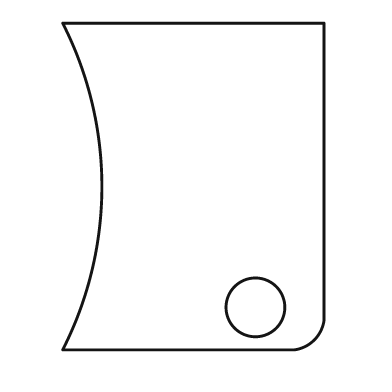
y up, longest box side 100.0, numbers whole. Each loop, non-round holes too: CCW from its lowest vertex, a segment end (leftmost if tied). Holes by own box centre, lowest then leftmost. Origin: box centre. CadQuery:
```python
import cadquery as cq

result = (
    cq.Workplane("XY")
    .moveTo(-40.0, -50.0)
    .lineTo(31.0, -50.0)
    .threePointArc((37.0, -47.0), (40.0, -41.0))
    .lineTo(40.0, 50.0)
    .lineTo(-40.0, 50.0)
    .threePointArc((-28.0, 0.0), (-40.0, -50.0))
    .close()
    .moveTo(19.0, -37.0)
    .circle(9.0)
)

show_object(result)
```